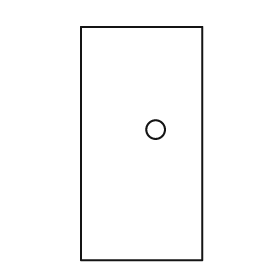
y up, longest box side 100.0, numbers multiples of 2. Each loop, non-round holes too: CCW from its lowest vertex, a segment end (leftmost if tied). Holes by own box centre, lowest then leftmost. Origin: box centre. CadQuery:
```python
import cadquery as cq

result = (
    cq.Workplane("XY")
    .moveTo(-26.0, -50.0)
    .lineTo(26.0, -50.0)
    .lineTo(26.0, 50.0)
    .lineTo(-26.0, 50.0)
    .close()
    .moveTo(6.0, 6.0)
    .circle(4.0)
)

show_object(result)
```